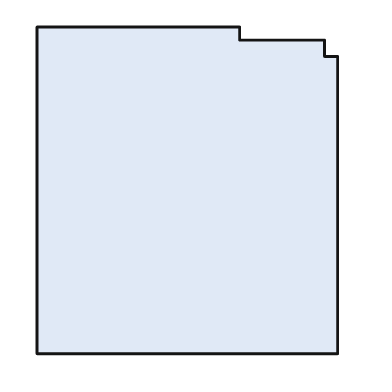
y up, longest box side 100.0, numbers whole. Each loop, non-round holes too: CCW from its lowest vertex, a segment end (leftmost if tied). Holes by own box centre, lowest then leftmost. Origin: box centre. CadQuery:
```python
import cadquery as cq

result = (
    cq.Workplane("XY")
    .moveTo(-46.0, -50.0)
    .lineTo(46.0, -50.0)
    .lineTo(46.0, 41.0)
    .lineTo(42.0, 41.0)
    .lineTo(42.0, 46.0)
    .lineTo(16.0, 46.0)
    .lineTo(16.0, 50.0)
    .lineTo(-46.0, 50.0)
    .close()
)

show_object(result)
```